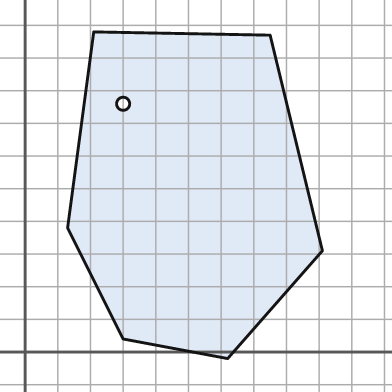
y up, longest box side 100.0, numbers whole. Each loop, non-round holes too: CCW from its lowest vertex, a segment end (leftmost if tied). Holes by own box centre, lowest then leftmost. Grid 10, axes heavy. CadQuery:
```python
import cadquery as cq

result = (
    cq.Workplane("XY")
    .moveTo(62.0, -2.0)
    .lineTo(91.0, 31.0)
    .lineTo(75.0, 97.0)
    .lineTo(21.0, 98.0)
    .lineTo(13.0, 38.0)
    .lineTo(30.0, 4.0)
    .close()
    .moveTo(30.0, 76.0)
    .circle(2.0)
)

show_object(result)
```